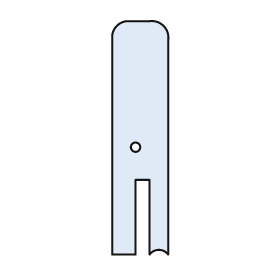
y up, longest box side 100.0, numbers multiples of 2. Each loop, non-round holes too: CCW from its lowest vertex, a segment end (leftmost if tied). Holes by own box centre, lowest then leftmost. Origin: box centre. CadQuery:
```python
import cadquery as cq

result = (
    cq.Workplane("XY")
    .moveTo(-12.0, -50.0)
    .lineTo(-2.0, -50.0)
    .lineTo(-2.0, -18.0)
    .lineTo(4.0, -18.0)
    .lineTo(4.0, -50.0)
    .threePointArc((8.0, -48.0), (12.0, -50.0))
    .lineTo(12.0, 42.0)
    .threePointArc((10.0, 48.0), (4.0, 50.0))
    .lineTo(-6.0, 50.0)
    .threePointArc((-10.0, 48.0), (-12.0, 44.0))
    .close()
    .moveTo(-2.0, -4.0)
    .circle(2.0)
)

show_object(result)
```